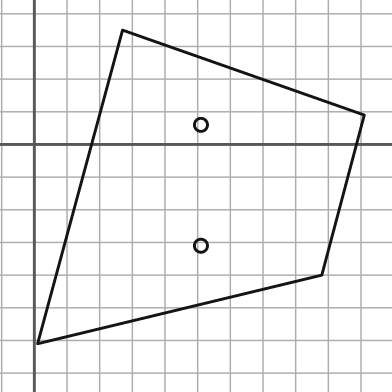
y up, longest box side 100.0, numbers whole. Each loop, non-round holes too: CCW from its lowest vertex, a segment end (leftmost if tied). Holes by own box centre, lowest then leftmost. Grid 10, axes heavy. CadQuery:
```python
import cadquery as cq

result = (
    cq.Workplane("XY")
    .moveTo(1.0, -61.0)
    .lineTo(88.0, -40.0)
    .lineTo(101.0, 9.0)
    .lineTo(27.0, 35.0)
    .close()
    .moveTo(51.0, -31.0)
    .circle(2.0)
    .moveTo(51.0, 6.0)
    .circle(2.0)
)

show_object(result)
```